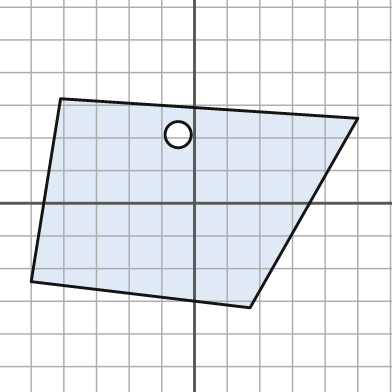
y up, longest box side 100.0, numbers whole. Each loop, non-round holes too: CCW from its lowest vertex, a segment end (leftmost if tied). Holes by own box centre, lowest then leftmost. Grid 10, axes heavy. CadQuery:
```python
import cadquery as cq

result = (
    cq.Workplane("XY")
    .moveTo(17.0, -32.0)
    .lineTo(50.0, 26.0)
    .lineTo(-41.0, 32.0)
    .lineTo(-50.0, -24.0)
    .close()
    .moveTo(-5.0, 21.0)
    .circle(4.0)
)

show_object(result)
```